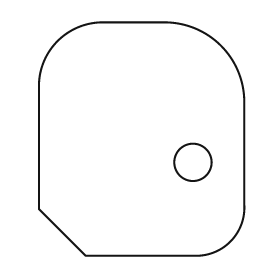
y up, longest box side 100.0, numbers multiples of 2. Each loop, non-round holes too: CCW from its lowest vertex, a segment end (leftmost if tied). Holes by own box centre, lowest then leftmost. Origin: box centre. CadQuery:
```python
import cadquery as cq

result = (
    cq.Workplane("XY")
    .moveTo(-24.0, -50.0)
    .lineTo(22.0, -50.0)
    .threePointArc((38.0, -44.0), (44.0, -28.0))
    .lineTo(44.0, 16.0)
    .threePointArc((34.0, 40.0), (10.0, 50.0))
    .lineTo(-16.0, 50.0)
    .threePointArc((-36.0, 42.0), (-44.0, 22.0))
    .lineTo(-44.0, -30.0)
    .close()
    .moveTo(22.0, -10.0)
    .circle(8.0)
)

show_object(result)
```